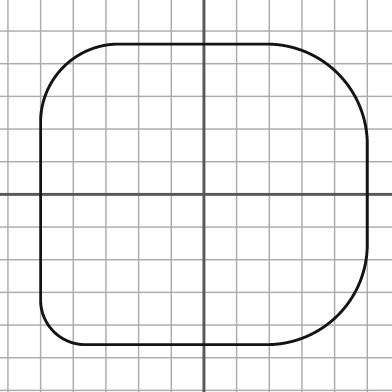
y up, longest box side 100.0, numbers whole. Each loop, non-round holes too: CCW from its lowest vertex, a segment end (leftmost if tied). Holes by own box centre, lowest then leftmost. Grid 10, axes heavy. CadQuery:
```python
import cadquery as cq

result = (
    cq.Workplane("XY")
    .moveTo(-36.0, -46.0)
    .lineTo(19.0, -46.0)
    .threePointArc((41.0, -37.0), (50.0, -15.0))
    .lineTo(50.0, 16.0)
    .threePointArc((41.0, 37.0), (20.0, 46.0))
    .lineTo(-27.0, 46.0)
    .threePointArc((-43.0, 39.0), (-50.0, 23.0))
    .lineTo(-50.0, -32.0)
    .threePointArc((-46.0, -42.0), (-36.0, -46.0))
    .close()
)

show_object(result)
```